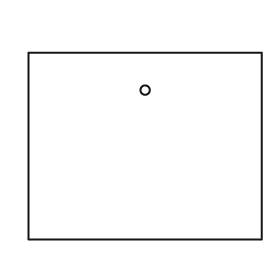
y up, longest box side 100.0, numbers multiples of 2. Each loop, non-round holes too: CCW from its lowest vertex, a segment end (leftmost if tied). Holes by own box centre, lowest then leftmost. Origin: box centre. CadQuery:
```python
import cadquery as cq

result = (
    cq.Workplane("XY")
    .moveTo(-50.0, -40.0)
    .lineTo(50.0, -40.0)
    .lineTo(50.0, 40.0)
    .lineTo(-50.0, 40.0)
    .close()
    .moveTo(0.0, 24.0)
    .circle(2.0)
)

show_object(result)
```